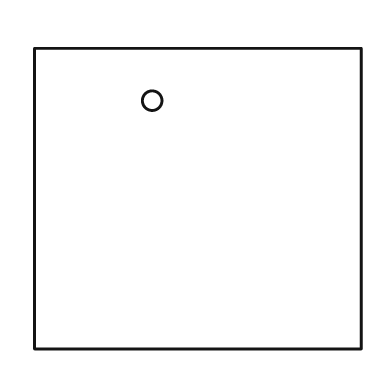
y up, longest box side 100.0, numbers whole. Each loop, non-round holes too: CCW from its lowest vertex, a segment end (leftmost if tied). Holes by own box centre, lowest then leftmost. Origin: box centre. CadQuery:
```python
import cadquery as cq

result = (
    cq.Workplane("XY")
    .moveTo(-50.0, -46.0)
    .lineTo(50.0, -46.0)
    .lineTo(50.0, 46.0)
    .lineTo(-50.0, 46.0)
    .close()
    .moveTo(-14.0, 30.0)
    .circle(3.0)
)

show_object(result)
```